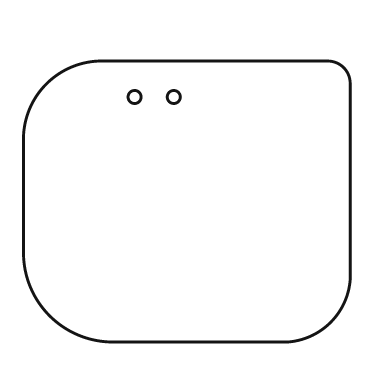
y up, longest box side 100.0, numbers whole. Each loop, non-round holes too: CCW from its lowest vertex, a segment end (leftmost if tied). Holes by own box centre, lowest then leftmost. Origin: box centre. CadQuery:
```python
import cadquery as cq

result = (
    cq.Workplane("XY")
    .moveTo(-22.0, -43.0)
    .lineTo(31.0, -43.0)
    .threePointArc((44.0, -37.0), (50.0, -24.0))
    .lineTo(50.0, 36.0)
    .threePointArc((48.0, 41.0), (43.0, 43.0))
    .lineTo(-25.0, 43.0)
    .threePointArc((-43.0, 36.0), (-50.0, 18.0))
    .lineTo(-50.0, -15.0)
    .threePointArc((-42.0, -35.0), (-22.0, -43.0))
    .close()
    .moveTo(-16.0, 32.0)
    .circle(2.0)
    .moveTo(-4.0, 32.0)
    .circle(2.0)
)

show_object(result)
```